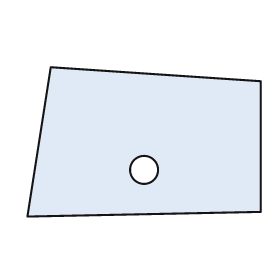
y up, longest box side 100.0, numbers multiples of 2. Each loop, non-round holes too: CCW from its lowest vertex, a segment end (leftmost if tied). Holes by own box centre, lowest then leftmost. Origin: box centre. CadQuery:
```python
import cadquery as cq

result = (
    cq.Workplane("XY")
    .moveTo(-50.0, -32.0)
    .lineTo(50.0, -30.0)
    .lineTo(50.0, 26.0)
    .lineTo(-40.0, 32.0)
    .close()
    .moveTo(0.0, -12.0)
    .circle(6.0)
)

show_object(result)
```